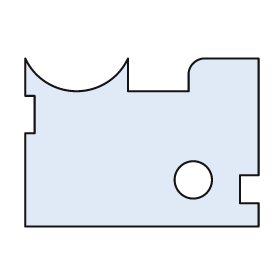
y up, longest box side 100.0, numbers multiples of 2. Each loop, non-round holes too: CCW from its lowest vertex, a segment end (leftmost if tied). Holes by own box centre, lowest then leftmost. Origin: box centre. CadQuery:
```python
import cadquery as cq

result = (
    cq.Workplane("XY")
    .moveTo(-50.0, -36.0)
    .lineTo(50.0, -36.0)
    .lineTo(50.0, -26.0)
    .lineTo(42.0, -26.0)
    .lineTo(42.0, -14.0)
    .lineTo(50.0, -14.0)
    .lineTo(50.0, 36.0)
    .lineTo(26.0, 36.0)
    .threePointArc((22.0, 34.0), (20.0, 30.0))
    .lineTo(20.0, 22.0)
    .lineTo(-6.0, 22.0)
    .lineTo(-6.0, 36.0)
    .threePointArc((-28.0, 22.0), (-50.0, 36.0))
    .lineTo(-50.0, 20.0)
    .lineTo(-46.0, 20.0)
    .lineTo(-46.0, 4.0)
    .lineTo(-50.0, 4.0)
    .close()
    .moveTo(22.0, -16.0)
    .circle(8.0)
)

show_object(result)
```